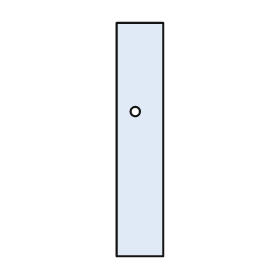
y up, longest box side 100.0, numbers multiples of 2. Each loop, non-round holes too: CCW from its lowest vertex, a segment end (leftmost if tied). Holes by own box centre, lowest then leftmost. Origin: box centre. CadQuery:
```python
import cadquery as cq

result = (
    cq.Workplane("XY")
    .moveTo(-10.0, -50.0)
    .lineTo(10.0, -50.0)
    .lineTo(10.0, 50.0)
    .lineTo(-10.0, 50.0)
    .close()
    .moveTo(-2.0, 12.0)
    .circle(2.0)
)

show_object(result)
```